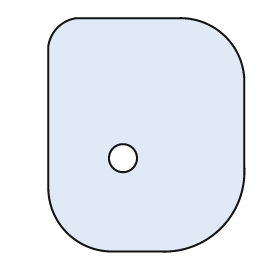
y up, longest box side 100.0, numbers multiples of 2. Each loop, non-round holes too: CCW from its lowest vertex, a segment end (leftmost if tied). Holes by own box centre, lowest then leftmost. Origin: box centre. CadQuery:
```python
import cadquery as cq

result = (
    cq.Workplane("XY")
    .moveTo(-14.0, -50.0)
    .lineTo(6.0, -50.0)
    .threePointArc((32.0, -40.0), (42.0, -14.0))
    .lineTo(42.0, 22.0)
    .threePointArc((34.0, 42.0), (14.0, 50.0))
    .lineTo(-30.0, 50.0)
    .threePointArc((-38.0, 46.0), (-42.0, 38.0))
    .lineTo(-42.0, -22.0)
    .threePointArc((-34.0, -42.0), (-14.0, -50.0))
    .close()
    .moveTo(-10.0, -10.0)
    .circle(6.0)
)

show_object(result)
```